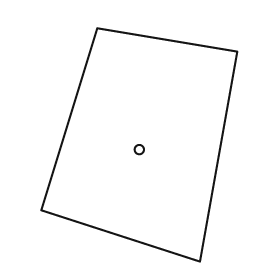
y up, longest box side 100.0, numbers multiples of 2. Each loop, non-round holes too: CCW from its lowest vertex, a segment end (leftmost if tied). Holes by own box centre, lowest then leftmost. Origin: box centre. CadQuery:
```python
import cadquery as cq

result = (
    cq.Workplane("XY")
    .moveTo(26.0, -50.0)
    .lineTo(42.0, 40.0)
    .lineTo(-18.0, 50.0)
    .lineTo(-42.0, -28.0)
    .close()
    .moveTo(0.0, -2.0)
    .circle(2.0)
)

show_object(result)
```